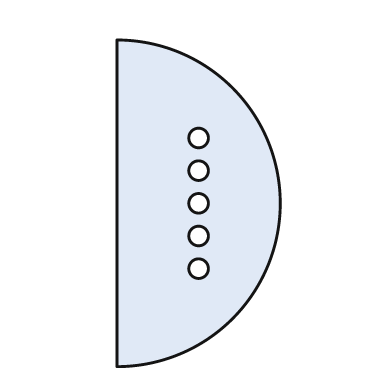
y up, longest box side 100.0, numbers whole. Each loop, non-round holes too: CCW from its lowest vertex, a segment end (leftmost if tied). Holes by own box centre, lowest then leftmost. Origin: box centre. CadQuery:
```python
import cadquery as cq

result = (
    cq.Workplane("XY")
    .moveTo(-25.0, -50.0)
    .threePointArc((25.0, 0.0), (-25.0, 50.0))
    .close()
    .moveTo(0.0, -20.0)
    .circle(3.0)
    .moveTo(0.0, -10.0)
    .circle(3.0)
    .moveTo(0.0, 0.0)
    .circle(3.0)
    .moveTo(0.0, 10.0)
    .circle(3.0)
    .moveTo(0.0, 20.0)
    .circle(3.0)
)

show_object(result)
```